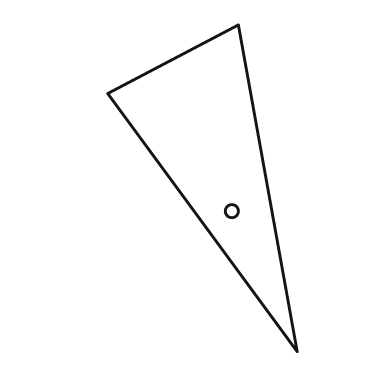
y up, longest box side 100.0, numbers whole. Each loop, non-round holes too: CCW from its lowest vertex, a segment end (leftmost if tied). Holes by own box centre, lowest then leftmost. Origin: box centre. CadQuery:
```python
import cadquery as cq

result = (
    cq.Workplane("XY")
    .moveTo(29.0, -50.0)
    .lineTo(11.0, 50.0)
    .lineTo(-29.0, 29.0)
    .close()
    .moveTo(9.0, -7.0)
    .circle(2.0)
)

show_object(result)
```